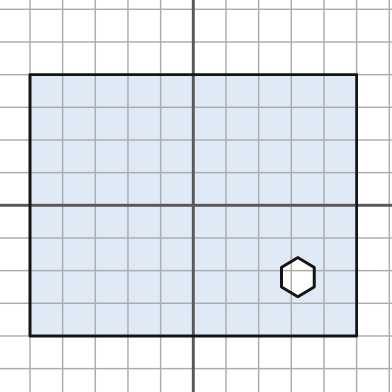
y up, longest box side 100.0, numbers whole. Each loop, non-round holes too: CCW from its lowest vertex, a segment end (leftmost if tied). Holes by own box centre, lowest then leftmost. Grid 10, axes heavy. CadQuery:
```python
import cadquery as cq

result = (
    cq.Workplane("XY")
    .moveTo(-50.0, -40.0)
    .lineTo(50.0, -40.0)
    .lineTo(50.0, 40.0)
    .lineTo(-50.0, 40.0)
    .close()
    .moveTo(32.0, -28.0)
    .lineTo(37.0, -25.0)
    .lineTo(37.0, -19.0)
    .lineTo(32.0, -16.0)
    .lineTo(27.0, -19.0)
    .lineTo(27.0, -25.0)
    .close()
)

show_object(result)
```